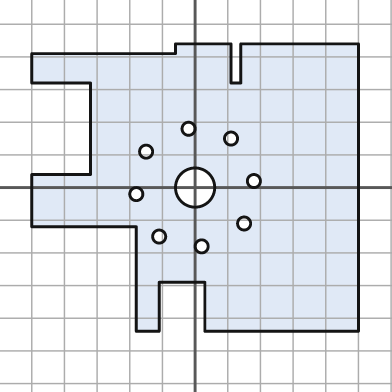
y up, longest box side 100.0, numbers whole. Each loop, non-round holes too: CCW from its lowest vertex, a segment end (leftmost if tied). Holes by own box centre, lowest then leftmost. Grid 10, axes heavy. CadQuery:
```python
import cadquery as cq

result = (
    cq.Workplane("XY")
    .moveTo(-18.0, -44.0)
    .lineTo(-11.0, -44.0)
    .lineTo(-11.0, -29.0)
    .lineTo(3.0, -29.0)
    .lineTo(3.0, -44.0)
    .lineTo(50.0, -44.0)
    .lineTo(50.0, 44.0)
    .lineTo(14.0, 44.0)
    .lineTo(14.0, 32.0)
    .lineTo(11.0, 32.0)
    .lineTo(11.0, 44.0)
    .lineTo(-6.0, 44.0)
    .lineTo(-6.0, 41.0)
    .lineTo(-50.0, 41.0)
    .lineTo(-50.0, 32.0)
    .lineTo(-32.0, 32.0)
    .lineTo(-32.0, 4.0)
    .lineTo(-50.0, 4.0)
    .lineTo(-50.0, -12.0)
    .lineTo(-18.0, -12.0)
    .close()
    .moveTo(2.0, -18.0)
    .circle(2.0)
    .moveTo(-11.0, -15.0)
    .circle(2.0)
    .moveTo(15.0, -11.0)
    .circle(2.0)
    .moveTo(-18.0, -2.0)
    .circle(2.0)
    .moveTo(0.0, 0.0)
    .circle(6.0)
    .moveTo(18.0, 2.0)
    .circle(2.0)
    .moveTo(-15.0, 11.0)
    .circle(2.0)
    .moveTo(11.0, 15.0)
    .circle(2.0)
    .moveTo(-2.0, 18.0)
    .circle(2.0)
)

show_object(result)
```